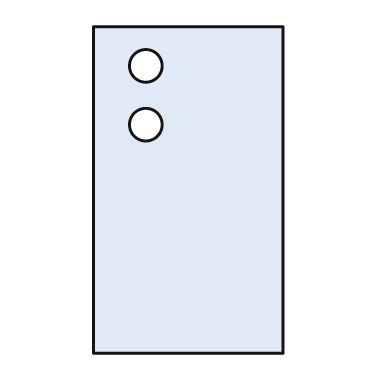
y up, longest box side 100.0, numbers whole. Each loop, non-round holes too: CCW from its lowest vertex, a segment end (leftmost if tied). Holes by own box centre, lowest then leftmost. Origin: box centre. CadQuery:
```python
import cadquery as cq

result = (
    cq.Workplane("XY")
    .moveTo(-29.0, -50.0)
    .lineTo(29.0, -50.0)
    .lineTo(29.0, 50.0)
    .lineTo(-29.0, 50.0)
    .close()
    .moveTo(-13.0, 20.0)
    .circle(5.0)
    .moveTo(-13.0, 38.0)
    .circle(5.0)
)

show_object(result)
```